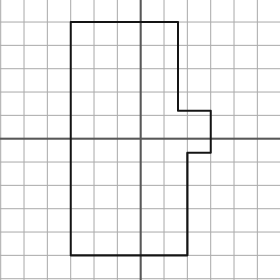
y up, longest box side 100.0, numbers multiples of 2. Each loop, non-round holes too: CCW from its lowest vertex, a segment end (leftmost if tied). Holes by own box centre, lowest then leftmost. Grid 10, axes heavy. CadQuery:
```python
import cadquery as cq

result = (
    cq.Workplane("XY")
    .moveTo(-30.0, -50.0)
    .lineTo(20.0, -50.0)
    .lineTo(20.0, -6.0)
    .lineTo(30.0, -6.0)
    .lineTo(30.0, 12.0)
    .lineTo(16.0, 12.0)
    .lineTo(16.0, 50.0)
    .lineTo(-30.0, 50.0)
    .close()
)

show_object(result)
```